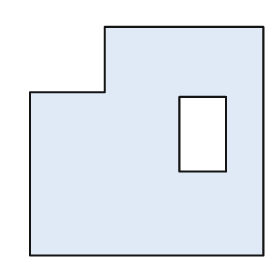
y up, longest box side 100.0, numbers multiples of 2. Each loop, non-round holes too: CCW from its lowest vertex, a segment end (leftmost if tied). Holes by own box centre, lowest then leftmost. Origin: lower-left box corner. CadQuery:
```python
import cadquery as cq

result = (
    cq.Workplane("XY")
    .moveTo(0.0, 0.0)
    .lineTo(100.0, 0.0)
    .lineTo(100.0, 98.0)
    .lineTo(32.0, 98.0)
    .lineTo(32.0, 70.0)
    .lineTo(0.0, 70.0)
    .close()
    .moveTo(64.0, 36.0)
    .lineTo(84.0, 36.0)
    .lineTo(84.0, 68.0)
    .lineTo(64.0, 68.0)
    .close()
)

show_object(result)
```